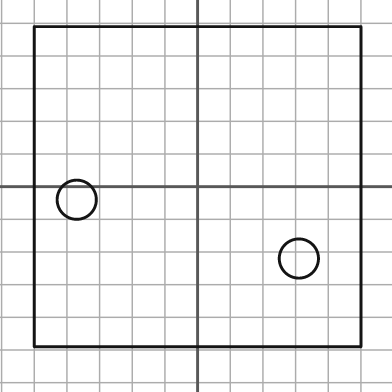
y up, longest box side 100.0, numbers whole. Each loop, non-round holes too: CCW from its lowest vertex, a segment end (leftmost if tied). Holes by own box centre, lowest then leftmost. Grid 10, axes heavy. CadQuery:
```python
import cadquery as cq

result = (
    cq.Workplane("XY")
    .moveTo(-50.0, -49.0)
    .lineTo(50.0, -49.0)
    .lineTo(50.0, 49.0)
    .lineTo(-50.0, 49.0)
    .close()
    .moveTo(31.0, -22.0)
    .circle(6.0)
    .moveTo(-37.0, -4.0)
    .circle(6.0)
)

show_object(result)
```